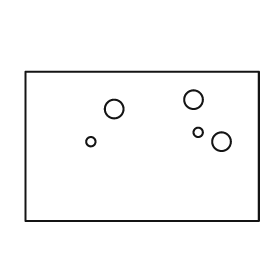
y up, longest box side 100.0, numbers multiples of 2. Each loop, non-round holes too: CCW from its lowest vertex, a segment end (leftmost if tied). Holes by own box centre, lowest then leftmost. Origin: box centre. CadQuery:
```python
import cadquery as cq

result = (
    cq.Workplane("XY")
    .moveTo(-50.0, -32.0)
    .lineTo(50.0, -32.0)
    .lineTo(50.0, 32.0)
    .lineTo(-50.0, 32.0)
    .close()
    .moveTo(-22.0, 2.0)
    .circle(2.0)
    .moveTo(34.0, 2.0)
    .circle(4.0)
    .moveTo(24.0, 6.0)
    .circle(2.0)
    .moveTo(-12.0, 16.0)
    .circle(4.0)
    .moveTo(22.0, 20.0)
    .circle(4.0)
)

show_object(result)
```